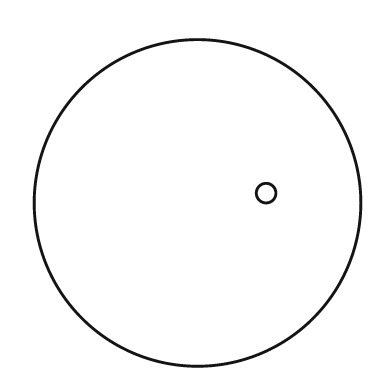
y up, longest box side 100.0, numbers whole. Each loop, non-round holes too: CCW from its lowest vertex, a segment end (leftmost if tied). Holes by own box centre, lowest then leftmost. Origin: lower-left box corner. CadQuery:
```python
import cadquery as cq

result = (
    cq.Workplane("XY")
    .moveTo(50.0, 50.0)
    .circle(50.0)
    .moveTo(71.0, 53.0)
    .circle(3.0)
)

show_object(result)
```